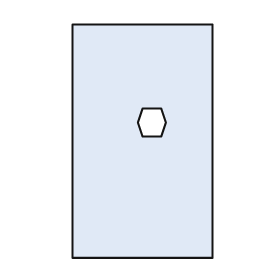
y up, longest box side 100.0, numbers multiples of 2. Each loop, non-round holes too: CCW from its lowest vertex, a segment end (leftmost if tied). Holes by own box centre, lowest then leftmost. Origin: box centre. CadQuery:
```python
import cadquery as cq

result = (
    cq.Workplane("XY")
    .moveTo(-30.0, -50.0)
    .lineTo(30.0, -50.0)
    .lineTo(30.0, 50.0)
    .lineTo(-30.0, 50.0)
    .close()
    .moveTo(0.0, 2.0)
    .lineTo(8.0, 2.0)
    .lineTo(10.0, 8.0)
    .lineTo(8.0, 14.0)
    .lineTo(0.0, 14.0)
    .lineTo(-2.0, 8.0)
    .close()
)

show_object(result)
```